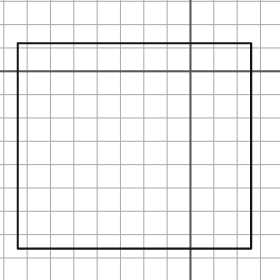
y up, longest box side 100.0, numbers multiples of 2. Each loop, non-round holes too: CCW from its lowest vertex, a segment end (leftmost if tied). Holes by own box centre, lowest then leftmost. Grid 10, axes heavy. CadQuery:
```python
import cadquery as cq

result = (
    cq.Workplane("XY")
    .moveTo(-74.0, -76.0)
    .lineTo(26.0, -76.0)
    .lineTo(26.0, 12.0)
    .lineTo(-74.0, 12.0)
    .close()
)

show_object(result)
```